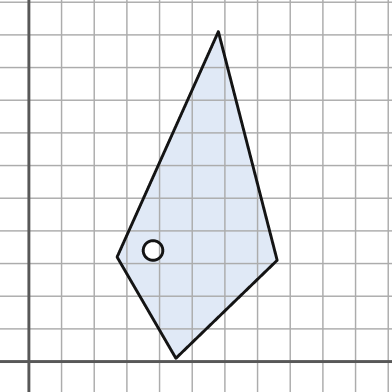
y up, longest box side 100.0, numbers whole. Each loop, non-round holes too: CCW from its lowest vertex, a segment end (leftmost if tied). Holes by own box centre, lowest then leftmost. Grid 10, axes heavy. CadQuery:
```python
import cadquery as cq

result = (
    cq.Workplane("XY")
    .moveTo(45.0, 1.0)
    .lineTo(76.0, 31.0)
    .lineTo(58.0, 101.0)
    .lineTo(27.0, 32.0)
    .close()
    .moveTo(38.0, 34.0)
    .circle(3.0)
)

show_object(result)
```